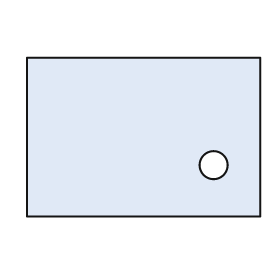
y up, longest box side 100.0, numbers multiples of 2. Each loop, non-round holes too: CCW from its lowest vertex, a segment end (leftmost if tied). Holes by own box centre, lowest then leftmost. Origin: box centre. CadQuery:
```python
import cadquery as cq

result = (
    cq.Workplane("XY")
    .moveTo(-50.0, -34.0)
    .lineTo(50.0, -34.0)
    .lineTo(50.0, 34.0)
    .lineTo(-50.0, 34.0)
    .close()
    .moveTo(30.0, -12.0)
    .circle(6.0)
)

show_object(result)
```